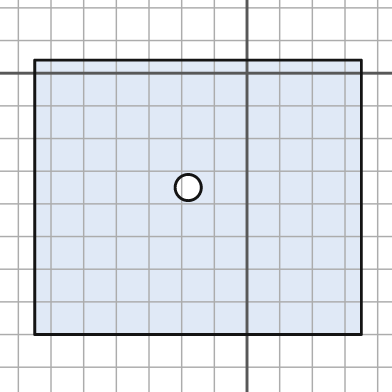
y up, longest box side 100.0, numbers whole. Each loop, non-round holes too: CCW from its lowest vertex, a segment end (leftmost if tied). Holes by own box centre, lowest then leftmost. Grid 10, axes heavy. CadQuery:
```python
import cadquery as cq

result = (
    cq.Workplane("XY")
    .moveTo(-65.0, -80.0)
    .lineTo(35.0, -80.0)
    .lineTo(35.0, 4.0)
    .lineTo(-65.0, 4.0)
    .close()
    .moveTo(-18.0, -35.0)
    .circle(4.0)
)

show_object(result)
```